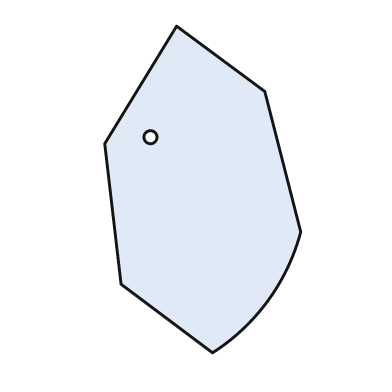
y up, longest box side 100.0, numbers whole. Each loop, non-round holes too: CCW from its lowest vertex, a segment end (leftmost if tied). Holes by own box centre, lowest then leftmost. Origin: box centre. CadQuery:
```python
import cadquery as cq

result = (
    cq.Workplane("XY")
    .moveTo(3.0, -50.0)
    .threePointArc((20.0, -34.0), (30.0, -13.0))
    .lineTo(19.0, 30.0)
    .lineTo(-8.0, 50.0)
    .lineTo(-30.0, 14.0)
    .lineTo(-25.0, -29.0)
    .close()
    .moveTo(-16.0, 16.0)
    .circle(2.0)
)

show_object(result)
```